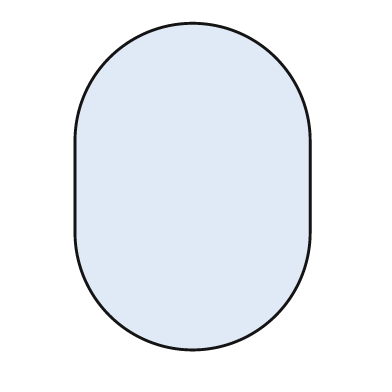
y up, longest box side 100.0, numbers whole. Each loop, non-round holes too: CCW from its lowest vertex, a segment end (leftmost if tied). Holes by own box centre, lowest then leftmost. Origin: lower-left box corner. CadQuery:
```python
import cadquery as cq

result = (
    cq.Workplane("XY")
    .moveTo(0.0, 36.0)
    .threePointArc((36.0, 0.0), (72.0, 36.0))
    .lineTo(72.0, 64.0)
    .threePointArc((36.0, 100.0), (0.0, 64.0))
    .close()
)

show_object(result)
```